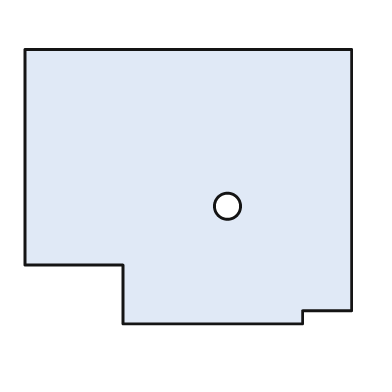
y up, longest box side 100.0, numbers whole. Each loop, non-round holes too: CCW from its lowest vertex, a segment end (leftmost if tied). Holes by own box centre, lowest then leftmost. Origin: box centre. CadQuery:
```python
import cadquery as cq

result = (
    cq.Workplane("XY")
    .moveTo(-20.0, -42.0)
    .lineTo(35.0, -42.0)
    .lineTo(35.0, -38.0)
    .lineTo(50.0, -38.0)
    .lineTo(50.0, 42.0)
    .lineTo(-50.0, 42.0)
    .lineTo(-50.0, -24.0)
    .lineTo(-20.0, -24.0)
    .close()
    .moveTo(12.0, -6.0)
    .circle(4.0)
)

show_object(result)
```